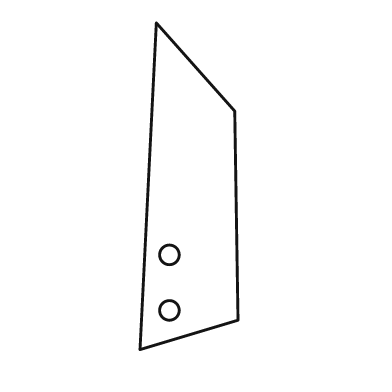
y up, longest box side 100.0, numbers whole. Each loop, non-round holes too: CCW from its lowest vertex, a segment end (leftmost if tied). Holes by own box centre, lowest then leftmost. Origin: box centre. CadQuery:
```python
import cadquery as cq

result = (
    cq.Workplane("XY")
    .moveTo(-15.0, -50.0)
    .lineTo(15.0, -41.0)
    .lineTo(14.0, 23.0)
    .lineTo(-10.0, 50.0)
    .close()
    .moveTo(-6.0, -38.0)
    .circle(3.0)
    .moveTo(-6.0, -21.0)
    .circle(3.0)
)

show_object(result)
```